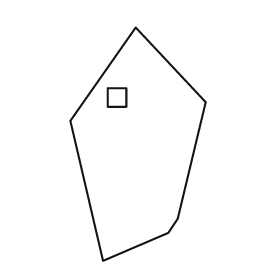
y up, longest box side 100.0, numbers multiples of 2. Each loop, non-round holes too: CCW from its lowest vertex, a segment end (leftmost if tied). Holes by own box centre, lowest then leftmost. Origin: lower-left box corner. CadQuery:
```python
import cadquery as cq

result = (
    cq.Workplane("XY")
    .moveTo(14.0, 0.0)
    .lineTo(42.0, 12.0)
    .lineTo(46.0, 18.0)
    .lineTo(58.0, 68.0)
    .lineTo(28.0, 100.0)
    .lineTo(0.0, 60.0)
    .close()
    .moveTo(16.0, 66.0)
    .lineTo(24.0, 66.0)
    .lineTo(24.0, 74.0)
    .lineTo(16.0, 74.0)
    .close()
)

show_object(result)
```